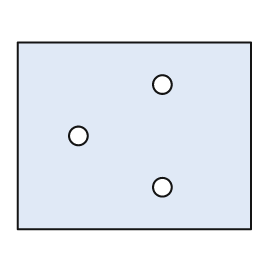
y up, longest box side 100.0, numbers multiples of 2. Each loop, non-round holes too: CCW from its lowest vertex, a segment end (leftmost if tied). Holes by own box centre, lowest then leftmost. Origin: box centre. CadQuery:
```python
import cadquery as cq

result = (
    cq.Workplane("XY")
    .moveTo(-50.0, -40.0)
    .lineTo(50.0, -40.0)
    .lineTo(50.0, 40.0)
    .lineTo(-50.0, 40.0)
    .close()
    .moveTo(12.0, -22.0)
    .circle(4.0)
    .moveTo(-24.0, 0.0)
    .circle(4.0)
    .moveTo(12.0, 22.0)
    .circle(4.0)
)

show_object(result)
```